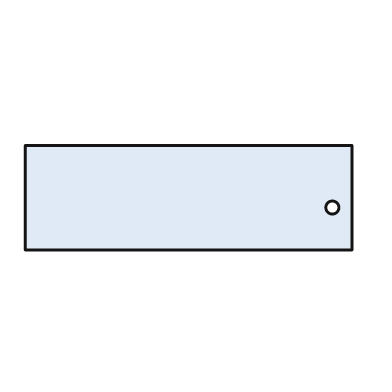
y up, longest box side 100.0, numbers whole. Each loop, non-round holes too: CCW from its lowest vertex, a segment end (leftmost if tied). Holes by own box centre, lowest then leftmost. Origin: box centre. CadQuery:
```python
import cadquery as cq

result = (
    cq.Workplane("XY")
    .moveTo(-50.0, -16.0)
    .lineTo(50.0, -16.0)
    .lineTo(50.0, 16.0)
    .lineTo(-50.0, 16.0)
    .close()
    .moveTo(44.0, -3.0)
    .circle(2.0)
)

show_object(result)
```